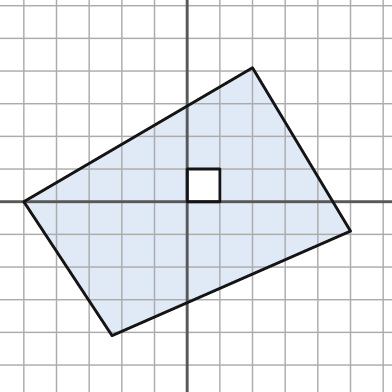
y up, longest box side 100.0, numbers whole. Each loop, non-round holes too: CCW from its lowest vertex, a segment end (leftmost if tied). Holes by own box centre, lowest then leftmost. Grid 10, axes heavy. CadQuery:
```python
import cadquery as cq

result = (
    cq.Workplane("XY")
    .moveTo(-23.0, -41.0)
    .lineTo(50.0, -9.0)
    .lineTo(20.0, 41.0)
    .lineTo(-50.0, 0.0)
    .close()
    .moveTo(0.0, 0.0)
    .lineTo(10.0, 0.0)
    .lineTo(10.0, 10.0)
    .lineTo(0.0, 10.0)
    .close()
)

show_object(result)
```